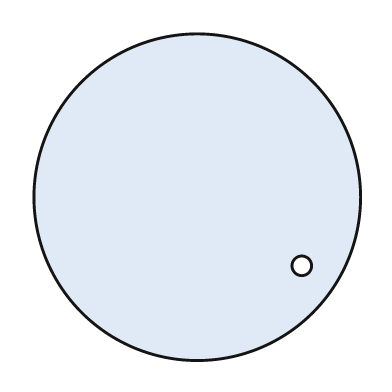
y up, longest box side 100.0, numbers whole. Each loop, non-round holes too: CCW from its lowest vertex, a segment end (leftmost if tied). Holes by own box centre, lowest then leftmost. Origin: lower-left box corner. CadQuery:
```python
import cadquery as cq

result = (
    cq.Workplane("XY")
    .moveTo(50.0, 50.0)
    .circle(50.0)
    .moveTo(82.0, 29.0)
    .circle(3.0)
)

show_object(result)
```